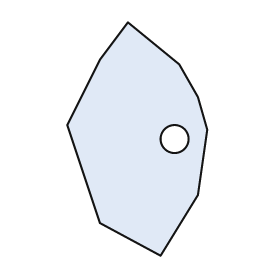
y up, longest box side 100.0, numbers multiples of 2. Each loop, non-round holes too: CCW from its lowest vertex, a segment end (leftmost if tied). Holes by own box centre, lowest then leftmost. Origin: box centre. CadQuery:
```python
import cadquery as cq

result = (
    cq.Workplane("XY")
    .moveTo(10.0, -50.0)
    .lineTo(26.0, -24.0)
    .lineTo(30.0, 4.0)
    .lineTo(26.0, 18.0)
    .lineTo(18.0, 32.0)
    .lineTo(-4.0, 50.0)
    .lineTo(-16.0, 34.0)
    .lineTo(-30.0, 6.0)
    .lineTo(-16.0, -36.0)
    .close()
    .moveTo(16.0, 0.0)
    .circle(6.0)
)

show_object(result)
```